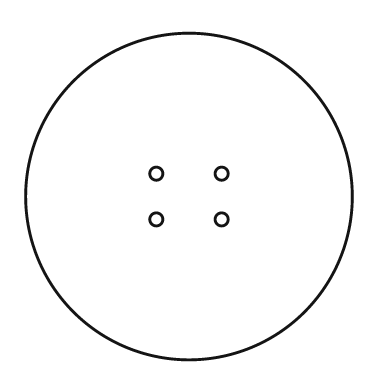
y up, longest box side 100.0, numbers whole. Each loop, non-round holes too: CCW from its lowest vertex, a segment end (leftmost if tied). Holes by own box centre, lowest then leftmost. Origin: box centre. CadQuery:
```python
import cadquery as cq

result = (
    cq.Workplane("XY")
    .moveTo(0.0, 0.0)
    .circle(50.0)
    .moveTo(-10.0, -7.0)
    .circle(2.0)
    .moveTo(10.0, -7.0)
    .circle(2.0)
    .moveTo(-10.0, 7.0)
    .circle(2.0)
    .moveTo(10.0, 7.0)
    .circle(2.0)
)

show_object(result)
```